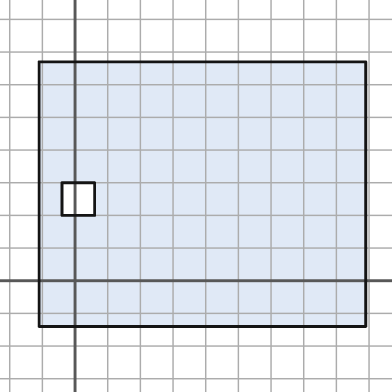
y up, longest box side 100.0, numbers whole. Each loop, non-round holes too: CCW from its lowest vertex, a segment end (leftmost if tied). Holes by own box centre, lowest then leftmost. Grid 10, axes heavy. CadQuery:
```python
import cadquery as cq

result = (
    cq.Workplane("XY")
    .moveTo(-11.0, -14.0)
    .lineTo(89.0, -14.0)
    .lineTo(89.0, 67.0)
    .lineTo(-11.0, 67.0)
    .close()
    .moveTo(-4.0, 20.0)
    .lineTo(6.0, 20.0)
    .lineTo(6.0, 30.0)
    .lineTo(-4.0, 30.0)
    .close()
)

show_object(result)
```